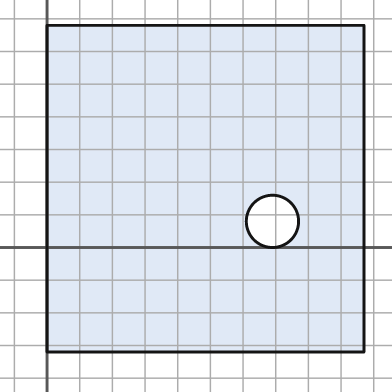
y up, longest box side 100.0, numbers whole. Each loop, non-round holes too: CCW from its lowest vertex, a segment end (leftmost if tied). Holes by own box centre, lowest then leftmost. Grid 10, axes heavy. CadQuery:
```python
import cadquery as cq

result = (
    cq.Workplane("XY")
    .moveTo(0.0, -32.0)
    .lineTo(97.0, -32.0)
    .lineTo(97.0, 68.0)
    .lineTo(0.0, 68.0)
    .close()
    .moveTo(69.0, 8.0)
    .circle(8.0)
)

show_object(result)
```